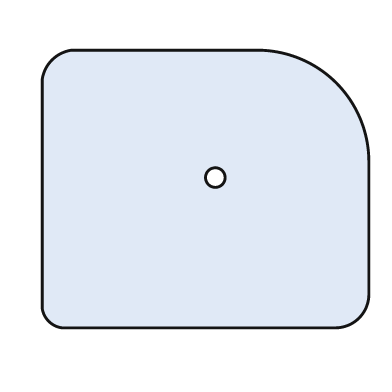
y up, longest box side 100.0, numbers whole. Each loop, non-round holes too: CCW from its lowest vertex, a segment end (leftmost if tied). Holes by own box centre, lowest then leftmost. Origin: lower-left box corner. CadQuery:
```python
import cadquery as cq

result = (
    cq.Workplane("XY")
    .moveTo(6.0, 0.0)
    .lineTo(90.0, 0.0)
    .threePointArc((97.0, 3.0), (100.0, 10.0))
    .lineTo(100.0, 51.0)
    .threePointArc((90.0, 75.0), (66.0, 85.0))
    .lineTo(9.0, 85.0)
    .threePointArc((3.0, 82.0), (0.0, 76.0))
    .lineTo(0.0, 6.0)
    .threePointArc((2.0, 2.0), (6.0, 0.0))
    .close()
    .moveTo(53.0, 46.0)
    .circle(3.0)
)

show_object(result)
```